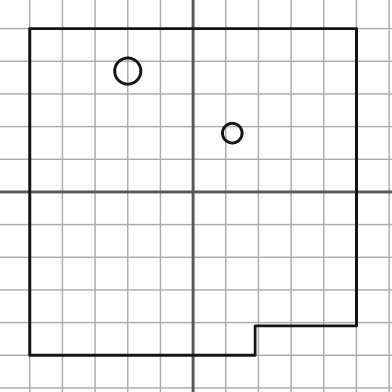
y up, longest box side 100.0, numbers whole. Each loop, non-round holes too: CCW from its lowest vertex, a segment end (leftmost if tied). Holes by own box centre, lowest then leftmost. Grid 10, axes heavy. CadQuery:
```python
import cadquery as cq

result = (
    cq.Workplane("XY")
    .moveTo(-50.0, -50.0)
    .lineTo(19.0, -50.0)
    .lineTo(19.0, -41.0)
    .lineTo(50.0, -41.0)
    .lineTo(50.0, 50.0)
    .lineTo(-50.0, 50.0)
    .close()
    .moveTo(12.0, 18.0)
    .circle(3.0)
    .moveTo(-20.0, 37.0)
    .circle(4.0)
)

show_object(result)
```